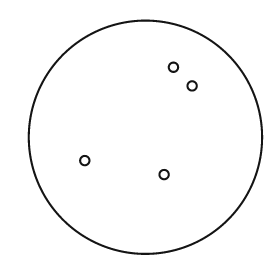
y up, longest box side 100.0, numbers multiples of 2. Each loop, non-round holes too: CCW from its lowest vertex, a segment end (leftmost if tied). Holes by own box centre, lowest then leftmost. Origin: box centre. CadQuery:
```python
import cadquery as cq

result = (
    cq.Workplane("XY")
    .moveTo(0.0, 0.0)
    .circle(50.0)
    .moveTo(8.0, -16.0)
    .circle(2.0)
    .moveTo(-26.0, -10.0)
    .circle(2.0)
    .moveTo(20.0, 22.0)
    .circle(2.0)
    .moveTo(12.0, 30.0)
    .circle(2.0)
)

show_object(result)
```